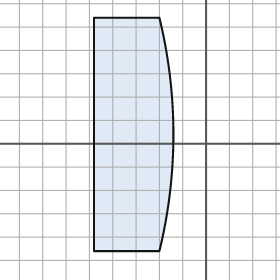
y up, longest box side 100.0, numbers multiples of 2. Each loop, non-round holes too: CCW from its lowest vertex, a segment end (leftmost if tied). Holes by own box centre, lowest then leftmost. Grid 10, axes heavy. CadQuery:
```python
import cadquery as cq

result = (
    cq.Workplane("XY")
    .moveTo(-48.0, -46.0)
    .lineTo(-20.0, -46.0)
    .threePointArc((-14.0, 4.0), (-20.0, 54.0))
    .lineTo(-48.0, 54.0)
    .close()
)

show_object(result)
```